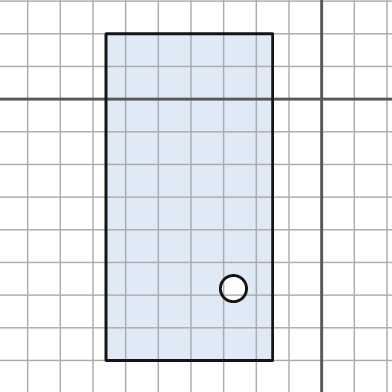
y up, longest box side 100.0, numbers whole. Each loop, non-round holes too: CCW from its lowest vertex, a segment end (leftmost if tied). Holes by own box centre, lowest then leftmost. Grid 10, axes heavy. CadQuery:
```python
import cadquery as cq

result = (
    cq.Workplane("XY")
    .moveTo(-66.0, -80.0)
    .lineTo(-15.0, -80.0)
    .lineTo(-15.0, 20.0)
    .lineTo(-66.0, 20.0)
    .close()
    .moveTo(-27.0, -58.0)
    .circle(4.0)
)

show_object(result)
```